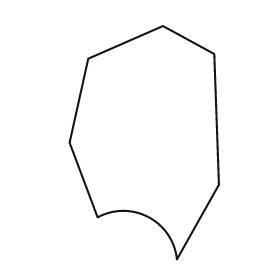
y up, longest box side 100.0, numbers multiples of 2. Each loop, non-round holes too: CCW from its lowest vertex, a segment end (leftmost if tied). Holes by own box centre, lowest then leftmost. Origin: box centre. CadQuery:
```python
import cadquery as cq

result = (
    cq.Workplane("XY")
    .moveTo(14.0, -50.0)
    .lineTo(32.0, -18.0)
    .lineTo(30.0, 38.0)
    .lineTo(8.0, 50.0)
    .lineTo(-24.0, 36.0)
    .lineTo(-32.0, 0.0)
    .lineTo(-20.0, -32.0)
    .threePointArc((2.0, -32.0), (14.0, -50.0))
    .close()
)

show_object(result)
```